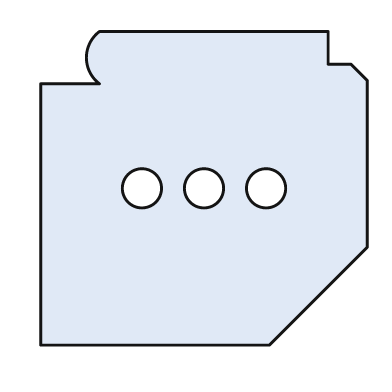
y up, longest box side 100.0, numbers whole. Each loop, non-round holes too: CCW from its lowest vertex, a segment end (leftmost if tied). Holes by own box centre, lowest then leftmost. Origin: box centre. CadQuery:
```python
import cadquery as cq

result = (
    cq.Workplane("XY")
    .moveTo(-50.0, -48.0)
    .lineTo(20.0, -48.0)
    .lineTo(50.0, -18.0)
    .lineTo(50.0, 33.0)
    .lineTo(45.0, 38.0)
    .lineTo(38.0, 38.0)
    .lineTo(38.0, 48.0)
    .lineTo(-32.0, 48.0)
    .threePointArc((-36.0, 40.0), (-32.0, 32.0))
    .lineTo(-50.0, 32.0)
    .close()
    .moveTo(-19.0, 0.0)
    .circle(6.0)
    .moveTo(0.0, 0.0)
    .circle(6.0)
    .moveTo(19.0, 0.0)
    .circle(6.0)
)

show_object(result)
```